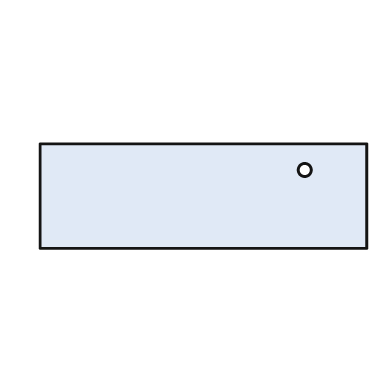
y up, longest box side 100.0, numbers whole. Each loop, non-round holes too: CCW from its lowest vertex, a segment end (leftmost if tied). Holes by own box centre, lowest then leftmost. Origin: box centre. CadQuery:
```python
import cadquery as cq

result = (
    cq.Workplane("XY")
    .moveTo(-50.0, -16.0)
    .lineTo(50.0, -16.0)
    .lineTo(50.0, 16.0)
    .lineTo(-50.0, 16.0)
    .close()
    .moveTo(31.0, 8.0)
    .circle(2.0)
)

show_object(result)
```